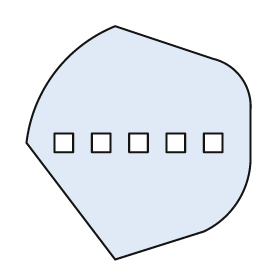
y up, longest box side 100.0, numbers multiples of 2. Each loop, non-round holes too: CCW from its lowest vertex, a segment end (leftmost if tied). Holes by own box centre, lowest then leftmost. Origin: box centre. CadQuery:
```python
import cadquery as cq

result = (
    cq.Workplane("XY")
    .moveTo(-10.0, -50.0)
    .lineTo(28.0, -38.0)
    .threePointArc((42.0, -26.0), (48.0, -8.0))
    .lineTo(48.0, 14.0)
    .threePointArc((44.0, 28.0), (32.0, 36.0))
    .lineTo(-10.0, 50.0)
    .threePointArc((-36.0, 30.0), (-48.0, 0.0))
    .close()
    .moveTo(-36.0, -4.0)
    .lineTo(-28.0, -4.0)
    .lineTo(-28.0, 4.0)
    .lineTo(-36.0, 4.0)
    .close()
    .moveTo(-20.0, -4.0)
    .lineTo(-12.0, -4.0)
    .lineTo(-12.0, 4.0)
    .lineTo(-20.0, 4.0)
    .close()
    .moveTo(-4.0, -4.0)
    .lineTo(4.0, -4.0)
    .lineTo(4.0, 4.0)
    .lineTo(-4.0, 4.0)
    .close()
    .moveTo(12.0, -4.0)
    .lineTo(20.0, -4.0)
    .lineTo(20.0, 4.0)
    .lineTo(12.0, 4.0)
    .close()
    .moveTo(28.0, -4.0)
    .lineTo(36.0, -4.0)
    .lineTo(36.0, 4.0)
    .lineTo(28.0, 4.0)
    .close()
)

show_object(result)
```